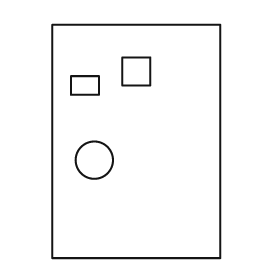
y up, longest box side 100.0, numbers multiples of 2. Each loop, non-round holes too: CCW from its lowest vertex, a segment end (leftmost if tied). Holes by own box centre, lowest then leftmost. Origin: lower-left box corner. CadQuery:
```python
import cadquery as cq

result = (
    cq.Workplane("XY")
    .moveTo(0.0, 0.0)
    .lineTo(72.0, 0.0)
    .lineTo(72.0, 100.0)
    .lineTo(0.0, 100.0)
    .close()
    .moveTo(18.0, 42.0)
    .circle(8.0)
    .moveTo(8.0, 70.0)
    .lineTo(20.0, 70.0)
    .lineTo(20.0, 78.0)
    .lineTo(8.0, 78.0)
    .close()
    .moveTo(30.0, 74.0)
    .lineTo(42.0, 74.0)
    .lineTo(42.0, 86.0)
    .lineTo(30.0, 86.0)
    .close()
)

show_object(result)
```